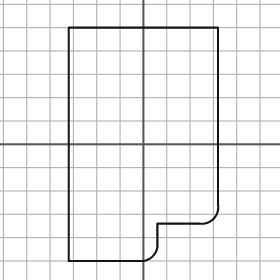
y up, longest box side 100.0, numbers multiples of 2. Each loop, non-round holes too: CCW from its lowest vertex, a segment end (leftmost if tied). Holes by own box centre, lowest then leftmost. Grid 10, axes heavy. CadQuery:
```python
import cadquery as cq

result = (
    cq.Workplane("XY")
    .moveTo(-32.0, -50.0)
    .lineTo(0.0, -50.0)
    .threePointArc((4.0, -48.0), (6.0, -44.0))
    .lineTo(6.0, -34.0)
    .lineTo(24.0, -34.0)
    .threePointArc((30.0, -32.0), (32.0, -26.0))
    .lineTo(32.0, 50.0)
    .lineTo(-32.0, 50.0)
    .close()
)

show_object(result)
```